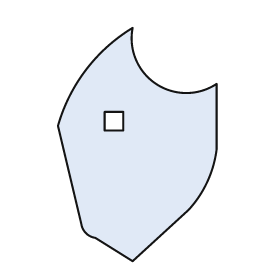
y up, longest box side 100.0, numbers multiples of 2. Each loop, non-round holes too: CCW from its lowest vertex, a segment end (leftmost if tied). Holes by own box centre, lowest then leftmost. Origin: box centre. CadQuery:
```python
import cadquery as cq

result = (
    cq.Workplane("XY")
    .moveTo(-2.0, -50.0)
    .lineTo(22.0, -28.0)
    .threePointArc((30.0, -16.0), (34.0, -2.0))
    .lineTo(34.0, 26.0)
    .threePointArc((8.0, 26.0), (-2.0, 50.0))
    .threePointArc((-22.0, 32.0), (-34.0, 8.0))
    .lineTo(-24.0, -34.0)
    .threePointArc((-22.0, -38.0), (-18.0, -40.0))
    .close()
    .moveTo(-14.0, 6.0)
    .lineTo(-6.0, 6.0)
    .lineTo(-6.0, 14.0)
    .lineTo(-14.0, 14.0)
    .close()
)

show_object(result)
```